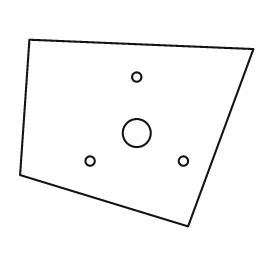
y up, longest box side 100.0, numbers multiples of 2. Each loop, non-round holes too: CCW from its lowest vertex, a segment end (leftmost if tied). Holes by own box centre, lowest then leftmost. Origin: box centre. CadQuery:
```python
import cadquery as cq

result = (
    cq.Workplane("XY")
    .moveTo(22.0, -40.0)
    .lineTo(50.0, 36.0)
    .lineTo(-46.0, 40.0)
    .lineTo(-50.0, -18.0)
    .close()
    .moveTo(-20.0, -12.0)
    .circle(2.0)
    .moveTo(20.0, -12.0)
    .circle(2.0)
    .moveTo(0.0, 0.0)
    .circle(6.0)
    .moveTo(0.0, 24.0)
    .circle(2.0)
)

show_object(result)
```